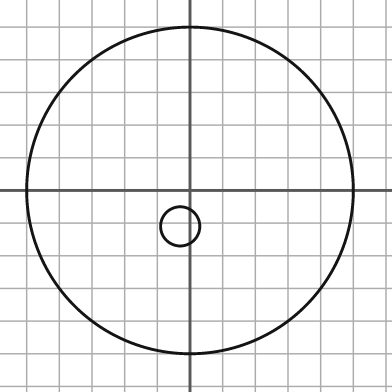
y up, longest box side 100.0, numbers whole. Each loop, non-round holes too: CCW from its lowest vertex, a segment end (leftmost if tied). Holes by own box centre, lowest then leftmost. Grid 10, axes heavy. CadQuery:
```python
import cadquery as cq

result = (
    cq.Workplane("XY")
    .moveTo(0.0, 0.0)
    .circle(50.0)
    .moveTo(-3.0, -11.0)
    .circle(6.0)
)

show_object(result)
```